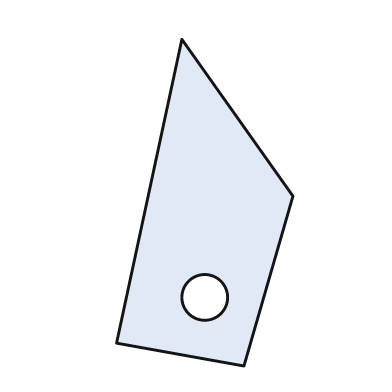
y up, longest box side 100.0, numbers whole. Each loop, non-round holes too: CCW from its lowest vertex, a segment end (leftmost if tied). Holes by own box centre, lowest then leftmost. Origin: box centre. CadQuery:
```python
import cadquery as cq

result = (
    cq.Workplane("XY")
    .moveTo(12.0, -50.0)
    .lineTo(27.0, 2.0)
    .lineTo(-7.0, 50.0)
    .lineTo(-27.0, -43.0)
    .close()
    .moveTo(0.0, -29.0)
    .circle(7.0)
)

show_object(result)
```